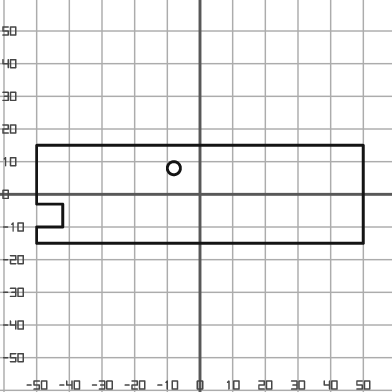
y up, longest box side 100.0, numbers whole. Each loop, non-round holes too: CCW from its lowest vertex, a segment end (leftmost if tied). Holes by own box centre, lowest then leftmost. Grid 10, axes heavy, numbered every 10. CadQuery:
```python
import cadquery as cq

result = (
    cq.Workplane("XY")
    .moveTo(-50.0, -15.0)
    .lineTo(50.0, -15.0)
    .lineTo(50.0, 15.0)
    .lineTo(-50.0, 15.0)
    .lineTo(-50.0, -3.0)
    .lineTo(-42.0, -3.0)
    .lineTo(-42.0, -10.0)
    .lineTo(-50.0, -10.0)
    .close()
    .moveTo(-8.0, 8.0)
    .circle(2.0)
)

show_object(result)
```